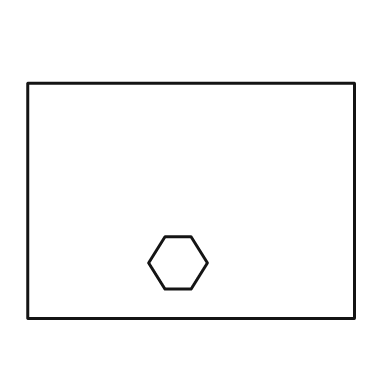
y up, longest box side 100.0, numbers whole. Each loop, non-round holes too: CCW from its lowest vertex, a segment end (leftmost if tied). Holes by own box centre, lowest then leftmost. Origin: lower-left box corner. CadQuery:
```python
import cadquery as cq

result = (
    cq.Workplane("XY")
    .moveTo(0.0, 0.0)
    .lineTo(100.0, 0.0)
    .lineTo(100.0, 72.0)
    .lineTo(0.0, 72.0)
    .close()
    .moveTo(42.0, 9.0)
    .lineTo(50.0, 9.0)
    .lineTo(55.0, 17.0)
    .lineTo(50.0, 25.0)
    .lineTo(42.0, 25.0)
    .lineTo(37.0, 17.0)
    .close()
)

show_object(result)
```